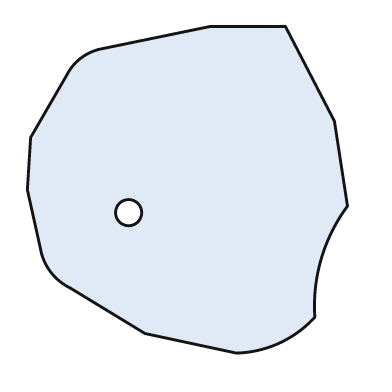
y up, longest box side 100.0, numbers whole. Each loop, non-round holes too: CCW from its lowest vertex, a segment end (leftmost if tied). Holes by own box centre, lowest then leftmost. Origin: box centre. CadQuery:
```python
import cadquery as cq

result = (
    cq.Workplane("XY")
    .moveTo(15.0, -50.0)
    .threePointArc((28.0, -47.0), (39.0, -39.0))
    .threePointArc((41.0, -21.0), (49.0, -5.0))
    .lineTo(45.0, 21.0)
    .lineTo(30.0, 50.0)
    .lineTo(7.0, 50.0)
    .lineTo(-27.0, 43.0)
    .threePointArc((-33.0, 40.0), (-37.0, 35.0))
    .lineTo(-48.0, 16.0)
    .lineTo(-49.0, 0.0)
    .lineTo(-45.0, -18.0)
    .threePointArc((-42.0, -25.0), (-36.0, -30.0))
    .lineTo(-13.0, -44.0)
    .close()
    .moveTo(-18.0, -7.0)
    .circle(4.0)
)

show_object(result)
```